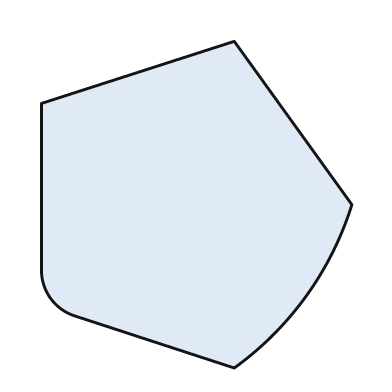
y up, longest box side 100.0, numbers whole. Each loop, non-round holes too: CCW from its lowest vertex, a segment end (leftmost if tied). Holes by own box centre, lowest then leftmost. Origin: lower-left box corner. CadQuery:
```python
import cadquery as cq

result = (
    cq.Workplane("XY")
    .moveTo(59.0, 0.0)
    .threePointArc((81.0, 22.0), (95.0, 50.0))
    .lineTo(59.0, 100.0)
    .lineTo(0.0, 81.0)
    .lineTo(0.0, 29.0)
    .threePointArc((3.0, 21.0), (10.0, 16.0))
    .close()
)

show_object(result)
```